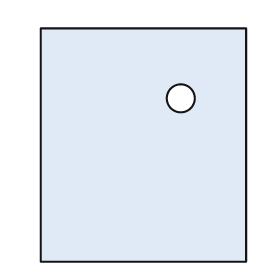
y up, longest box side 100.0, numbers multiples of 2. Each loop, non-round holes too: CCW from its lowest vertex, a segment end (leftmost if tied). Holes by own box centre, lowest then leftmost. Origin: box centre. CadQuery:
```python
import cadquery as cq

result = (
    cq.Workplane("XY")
    .moveTo(-44.0, -50.0)
    .lineTo(44.0, -50.0)
    .lineTo(44.0, 50.0)
    .lineTo(-44.0, 50.0)
    .close()
    .moveTo(16.0, 20.0)
    .circle(6.0)
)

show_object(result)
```